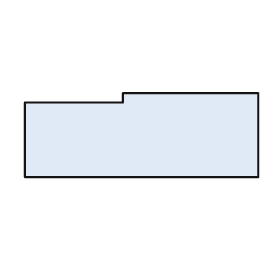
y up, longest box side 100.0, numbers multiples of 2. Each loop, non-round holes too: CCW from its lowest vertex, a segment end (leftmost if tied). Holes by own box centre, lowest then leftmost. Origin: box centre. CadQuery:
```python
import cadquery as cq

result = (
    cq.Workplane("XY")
    .moveTo(-50.0, -18.0)
    .lineTo(50.0, -18.0)
    .lineTo(50.0, 18.0)
    .lineTo(-8.0, 18.0)
    .lineTo(-8.0, 14.0)
    .lineTo(-50.0, 14.0)
    .close()
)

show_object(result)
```